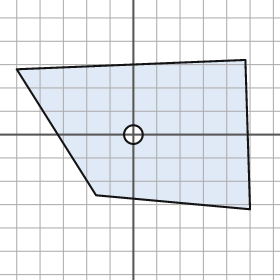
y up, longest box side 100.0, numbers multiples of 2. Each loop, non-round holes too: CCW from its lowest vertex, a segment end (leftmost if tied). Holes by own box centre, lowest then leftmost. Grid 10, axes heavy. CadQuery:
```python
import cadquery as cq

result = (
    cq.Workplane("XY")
    .moveTo(50.0, -32.0)
    .lineTo(48.0, 32.0)
    .lineTo(-50.0, 28.0)
    .lineTo(-16.0, -26.0)
    .close()
    .moveTo(0.0, 0.0)
    .circle(4.0)
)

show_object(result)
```